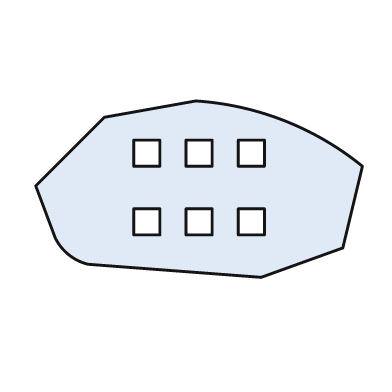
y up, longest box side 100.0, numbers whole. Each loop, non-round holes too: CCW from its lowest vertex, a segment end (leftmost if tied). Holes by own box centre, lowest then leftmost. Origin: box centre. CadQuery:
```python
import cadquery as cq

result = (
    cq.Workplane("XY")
    .moveTo(19.0, -27.0)
    .lineTo(44.0, -18.0)
    .lineTo(50.0, 7.0)
    .threePointArc((26.0, 21.0), (-1.0, 27.0))
    .lineTo(-29.0, 22.0)
    .lineTo(-50.0, 1.0)
    .lineTo(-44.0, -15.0)
    .threePointArc((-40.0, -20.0), (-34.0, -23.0))
    .close()
    .moveTo(-20.0, -14.0)
    .lineTo(-12.0, -14.0)
    .lineTo(-12.0, -6.0)
    .lineTo(-20.0, -6.0)
    .close()
    .moveTo(-4.0, -14.0)
    .lineTo(4.0, -14.0)
    .lineTo(4.0, -6.0)
    .lineTo(-4.0, -6.0)
    .close()
    .moveTo(12.0, -14.0)
    .lineTo(20.0, -14.0)
    .lineTo(20.0, -6.0)
    .lineTo(12.0, -6.0)
    .close()
    .moveTo(-20.0, 7.0)
    .lineTo(-12.0, 7.0)
    .lineTo(-12.0, 15.0)
    .lineTo(-20.0, 15.0)
    .close()
    .moveTo(-4.0, 7.0)
    .lineTo(4.0, 7.0)
    .lineTo(4.0, 15.0)
    .lineTo(-4.0, 15.0)
    .close()
    .moveTo(12.0, 7.0)
    .lineTo(20.0, 7.0)
    .lineTo(20.0, 15.0)
    .lineTo(12.0, 15.0)
    .close()
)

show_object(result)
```